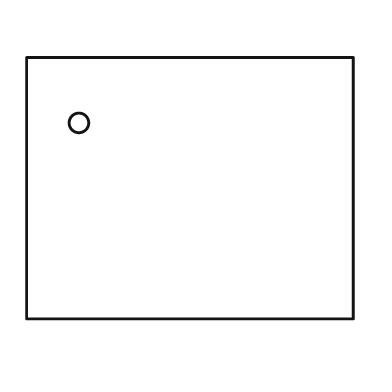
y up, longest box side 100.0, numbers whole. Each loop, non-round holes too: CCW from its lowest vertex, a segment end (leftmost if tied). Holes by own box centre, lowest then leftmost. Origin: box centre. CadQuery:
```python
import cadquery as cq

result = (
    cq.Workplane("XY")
    .moveTo(-50.0, -40.0)
    .lineTo(50.0, -40.0)
    .lineTo(50.0, 40.0)
    .lineTo(-50.0, 40.0)
    .close()
    .moveTo(-34.0, 20.0)
    .circle(3.0)
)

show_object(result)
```